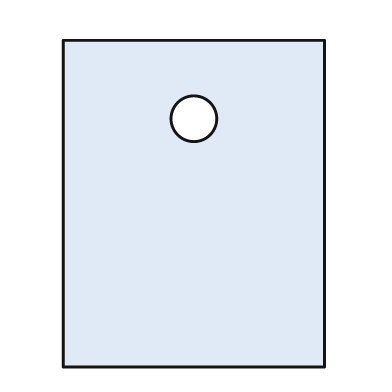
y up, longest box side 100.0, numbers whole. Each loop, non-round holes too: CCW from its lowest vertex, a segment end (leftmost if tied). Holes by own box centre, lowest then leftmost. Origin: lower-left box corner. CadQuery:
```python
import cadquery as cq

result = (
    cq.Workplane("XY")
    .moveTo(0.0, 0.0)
    .lineTo(80.0, 0.0)
    .lineTo(80.0, 100.0)
    .lineTo(0.0, 100.0)
    .close()
    .moveTo(40.0, 76.0)
    .circle(7.0)
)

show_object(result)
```